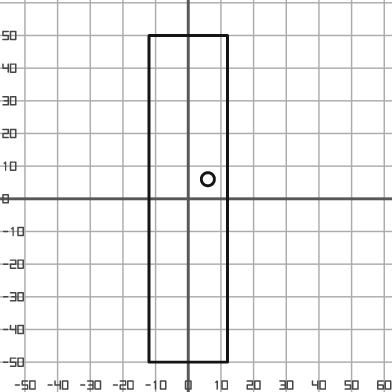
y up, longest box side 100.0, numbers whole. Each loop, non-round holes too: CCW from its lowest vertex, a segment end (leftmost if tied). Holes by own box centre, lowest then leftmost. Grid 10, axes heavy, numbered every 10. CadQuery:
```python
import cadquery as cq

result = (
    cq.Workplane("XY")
    .moveTo(-12.0, -50.0)
    .lineTo(12.0, -50.0)
    .lineTo(12.0, 50.0)
    .lineTo(-12.0, 50.0)
    .close()
    .moveTo(6.0, 6.0)
    .circle(2.0)
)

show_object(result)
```